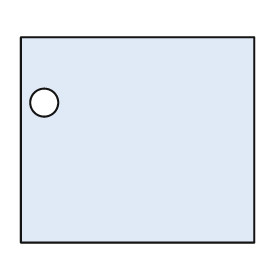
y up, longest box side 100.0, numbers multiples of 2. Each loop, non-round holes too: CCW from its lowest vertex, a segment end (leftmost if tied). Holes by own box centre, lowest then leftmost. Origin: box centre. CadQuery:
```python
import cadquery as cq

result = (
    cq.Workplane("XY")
    .moveTo(-50.0, -44.0)
    .lineTo(50.0, -44.0)
    .lineTo(50.0, 44.0)
    .lineTo(-50.0, 44.0)
    .close()
    .moveTo(-40.0, 16.0)
    .circle(6.0)
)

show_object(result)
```